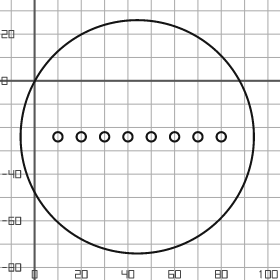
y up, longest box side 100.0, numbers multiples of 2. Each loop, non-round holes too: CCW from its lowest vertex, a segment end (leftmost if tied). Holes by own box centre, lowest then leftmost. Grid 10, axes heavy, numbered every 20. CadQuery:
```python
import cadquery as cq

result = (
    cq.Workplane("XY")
    .moveTo(44.0, -24.0)
    .circle(50.0)
    .moveTo(10.0, -24.0)
    .circle(2.0)
    .moveTo(20.0, -24.0)
    .circle(2.0)
    .moveTo(30.0, -24.0)
    .circle(2.0)
    .moveTo(40.0, -24.0)
    .circle(2.0)
    .moveTo(50.0, -24.0)
    .circle(2.0)
    .moveTo(60.0, -24.0)
    .circle(2.0)
    .moveTo(70.0, -24.0)
    .circle(2.0)
    .moveTo(80.0, -24.0)
    .circle(2.0)
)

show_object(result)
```